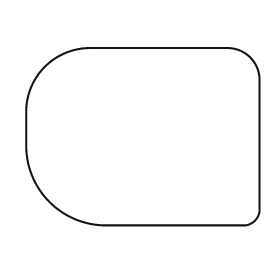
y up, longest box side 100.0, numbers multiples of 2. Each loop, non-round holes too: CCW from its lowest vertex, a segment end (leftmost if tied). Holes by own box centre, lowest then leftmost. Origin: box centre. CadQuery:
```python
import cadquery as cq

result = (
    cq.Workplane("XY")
    .moveTo(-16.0, -38.0)
    .lineTo(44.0, -38.0)
    .threePointArc((48.0, -36.0), (50.0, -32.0))
    .lineTo(50.0, 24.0)
    .threePointArc((46.0, 34.0), (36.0, 38.0))
    .lineTo(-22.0, 38.0)
    .threePointArc((-42.0, 30.0), (-50.0, 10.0))
    .lineTo(-50.0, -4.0)
    .threePointArc((-40.0, -28.0), (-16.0, -38.0))
    .close()
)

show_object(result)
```